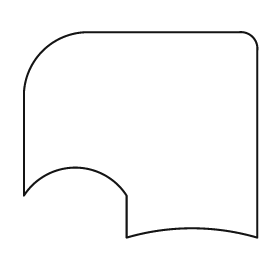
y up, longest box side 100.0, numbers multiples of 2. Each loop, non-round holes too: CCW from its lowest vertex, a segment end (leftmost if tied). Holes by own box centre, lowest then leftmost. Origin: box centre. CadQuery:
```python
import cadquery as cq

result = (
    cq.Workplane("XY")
    .moveTo(-6.0, -44.0)
    .threePointArc((22.0, -40.0), (50.0, -44.0))
    .lineTo(50.0, 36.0)
    .threePointArc((48.0, 42.0), (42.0, 44.0))
    .lineTo(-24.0, 44.0)
    .threePointArc((-42.0, 36.0), (-50.0, 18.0))
    .lineTo(-50.0, -26.0)
    .threePointArc((-28.0, -14.0), (-6.0, -26.0))
    .close()
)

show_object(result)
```